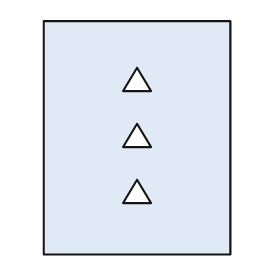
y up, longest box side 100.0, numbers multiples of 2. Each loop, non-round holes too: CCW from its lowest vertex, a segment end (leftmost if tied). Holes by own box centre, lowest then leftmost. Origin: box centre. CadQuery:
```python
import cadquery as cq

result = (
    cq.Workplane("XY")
    .moveTo(-40.0, -50.0)
    .lineTo(40.0, -50.0)
    .lineTo(40.0, 50.0)
    .lineTo(-40.0, 50.0)
    .close()
    .moveTo(-6.0, -28.0)
    .lineTo(6.0, -28.0)
    .lineTo(0.0, -18.0)
    .close()
    .moveTo(-6.0, -4.0)
    .lineTo(6.0, -4.0)
    .lineTo(0.0, 6.0)
    .close()
    .moveTo(-6.0, 20.0)
    .lineTo(6.0, 20.0)
    .lineTo(0.0, 30.0)
    .close()
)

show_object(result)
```